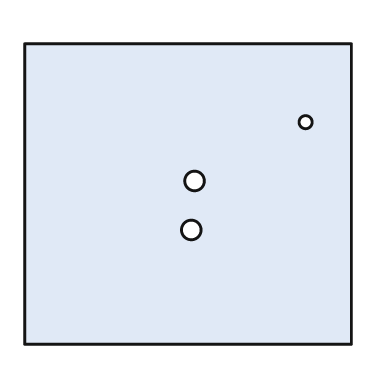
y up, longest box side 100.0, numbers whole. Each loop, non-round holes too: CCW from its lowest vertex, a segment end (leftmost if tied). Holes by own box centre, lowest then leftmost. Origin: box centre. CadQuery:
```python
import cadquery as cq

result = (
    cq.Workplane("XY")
    .moveTo(-50.0, -46.0)
    .lineTo(50.0, -46.0)
    .lineTo(50.0, 46.0)
    .lineTo(-50.0, 46.0)
    .close()
    .moveTo(1.0, -11.0)
    .circle(3.0)
    .moveTo(2.0, 4.0)
    .circle(3.0)
    .moveTo(36.0, 22.0)
    .circle(2.0)
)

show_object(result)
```